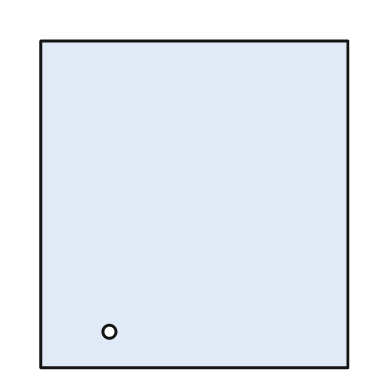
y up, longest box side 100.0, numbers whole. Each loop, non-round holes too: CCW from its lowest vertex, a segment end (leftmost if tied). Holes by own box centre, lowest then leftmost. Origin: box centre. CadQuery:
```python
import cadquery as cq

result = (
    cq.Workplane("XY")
    .moveTo(-47.0, -50.0)
    .lineTo(47.0, -50.0)
    .lineTo(47.0, 50.0)
    .lineTo(-47.0, 50.0)
    .close()
    .moveTo(-26.0, -39.0)
    .circle(2.0)
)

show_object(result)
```